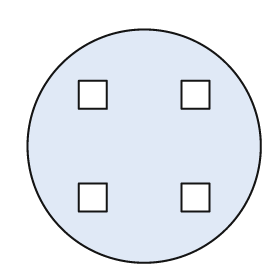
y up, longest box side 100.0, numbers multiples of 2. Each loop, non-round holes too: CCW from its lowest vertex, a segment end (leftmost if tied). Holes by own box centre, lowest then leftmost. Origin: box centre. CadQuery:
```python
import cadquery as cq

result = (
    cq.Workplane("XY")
    .moveTo(0.0, 0.0)
    .circle(50.0)
    .moveTo(-28.0, -28.0)
    .lineTo(-16.0, -28.0)
    .lineTo(-16.0, -16.0)
    .lineTo(-28.0, -16.0)
    .close()
    .moveTo(16.0, -28.0)
    .lineTo(28.0, -28.0)
    .lineTo(28.0, -16.0)
    .lineTo(16.0, -16.0)
    .close()
    .moveTo(-28.0, 16.0)
    .lineTo(-16.0, 16.0)
    .lineTo(-16.0, 28.0)
    .lineTo(-28.0, 28.0)
    .close()
    .moveTo(16.0, 16.0)
    .lineTo(28.0, 16.0)
    .lineTo(28.0, 28.0)
    .lineTo(16.0, 28.0)
    .close()
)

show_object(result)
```